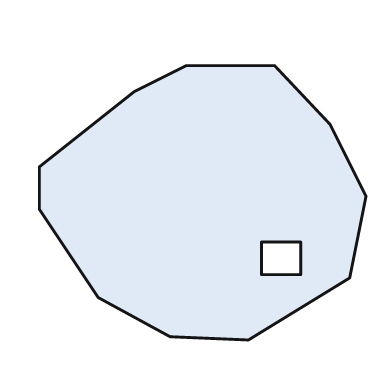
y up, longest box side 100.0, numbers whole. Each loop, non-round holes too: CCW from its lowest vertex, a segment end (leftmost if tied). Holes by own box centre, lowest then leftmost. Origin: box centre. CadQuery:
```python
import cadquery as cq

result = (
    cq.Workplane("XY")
    .moveTo(14.0, -42.0)
    .lineTo(45.0, -23.0)
    .lineTo(50.0, 2.0)
    .lineTo(39.0, 24.0)
    .lineTo(22.0, 42.0)
    .lineTo(-5.0, 42.0)
    .lineTo(-21.0, 34.0)
    .lineTo(-50.0, 11.0)
    .lineTo(-50.0, -2.0)
    .lineTo(-32.0, -29.0)
    .lineTo(-10.0, -41.0)
    .close()
    .moveTo(18.0, -22.0)
    .lineTo(30.0, -22.0)
    .lineTo(30.0, -12.0)
    .lineTo(18.0, -12.0)
    .close()
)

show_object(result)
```